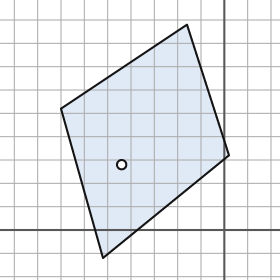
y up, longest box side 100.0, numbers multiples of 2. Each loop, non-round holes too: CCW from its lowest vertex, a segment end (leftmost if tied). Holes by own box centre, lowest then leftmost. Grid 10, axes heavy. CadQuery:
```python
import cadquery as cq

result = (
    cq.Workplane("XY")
    .moveTo(-52.0, -12.0)
    .lineTo(2.0, 32.0)
    .lineTo(-16.0, 88.0)
    .lineTo(-70.0, 52.0)
    .close()
    .moveTo(-44.0, 28.0)
    .circle(2.0)
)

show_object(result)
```